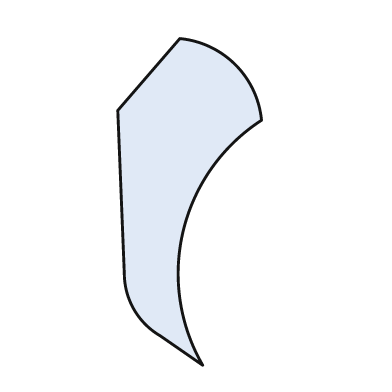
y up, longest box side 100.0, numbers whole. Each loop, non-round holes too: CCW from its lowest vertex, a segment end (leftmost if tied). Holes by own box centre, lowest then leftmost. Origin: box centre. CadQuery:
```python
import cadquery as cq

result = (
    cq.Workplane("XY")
    .moveTo(4.0, -50.0)
    .threePointArc((-2.0, -9.0), (22.0, 25.0))
    .threePointArc((14.0, 42.0), (-3.0, 50.0))
    .lineTo(-22.0, 28.0)
    .lineTo(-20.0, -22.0)
    .threePointArc((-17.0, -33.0), (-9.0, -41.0))
    .close()
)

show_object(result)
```